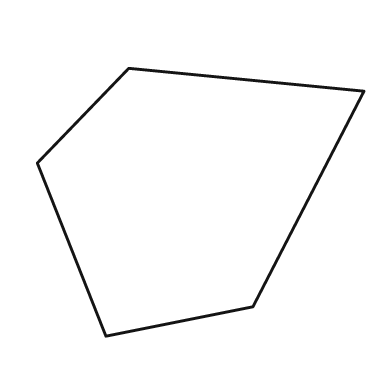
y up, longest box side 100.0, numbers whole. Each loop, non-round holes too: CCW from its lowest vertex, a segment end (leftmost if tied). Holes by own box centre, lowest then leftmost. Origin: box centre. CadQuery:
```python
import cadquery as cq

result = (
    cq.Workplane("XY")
    .moveTo(-29.0, -41.0)
    .lineTo(16.0, -32.0)
    .lineTo(50.0, 34.0)
    .lineTo(-22.0, 41.0)
    .lineTo(-50.0, 12.0)
    .close()
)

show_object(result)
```